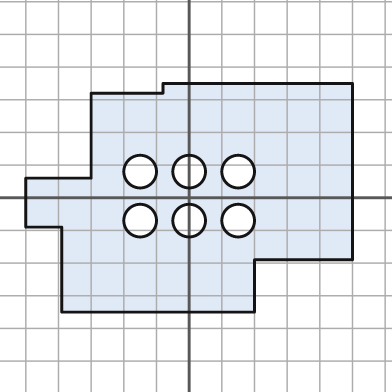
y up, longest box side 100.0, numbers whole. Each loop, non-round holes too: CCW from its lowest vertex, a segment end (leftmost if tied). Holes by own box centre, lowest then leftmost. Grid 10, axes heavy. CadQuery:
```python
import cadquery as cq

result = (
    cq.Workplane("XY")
    .moveTo(-39.0, -35.0)
    .lineTo(20.0, -35.0)
    .lineTo(20.0, -19.0)
    .lineTo(50.0, -19.0)
    .lineTo(50.0, 35.0)
    .lineTo(-8.0, 35.0)
    .lineTo(-8.0, 32.0)
    .lineTo(-30.0, 32.0)
    .lineTo(-30.0, 6.0)
    .lineTo(-50.0, 6.0)
    .lineTo(-50.0, -9.0)
    .lineTo(-39.0, -9.0)
    .close()
    .moveTo(-15.0, -7.0)
    .circle(5.0)
    .moveTo(0.0, -7.0)
    .circle(5.0)
    .moveTo(15.0, -7.0)
    .circle(5.0)
    .moveTo(-15.0, 8.0)
    .circle(5.0)
    .moveTo(0.0, 8.0)
    .circle(5.0)
    .moveTo(15.0, 8.0)
    .circle(5.0)
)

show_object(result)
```